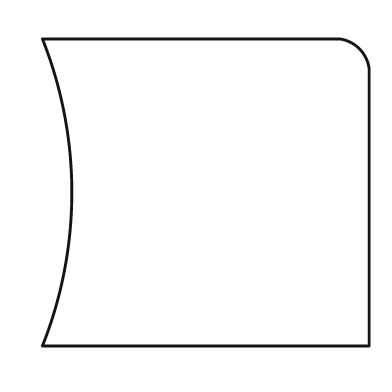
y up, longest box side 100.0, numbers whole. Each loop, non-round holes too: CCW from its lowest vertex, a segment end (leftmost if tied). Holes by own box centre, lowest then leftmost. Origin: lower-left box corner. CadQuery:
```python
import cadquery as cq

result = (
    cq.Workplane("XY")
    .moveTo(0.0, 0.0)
    .lineTo(100.0, 0.0)
    .lineTo(100.0, 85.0)
    .threePointArc((97.0, 91.0), (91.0, 94.0))
    .lineTo(0.0, 94.0)
    .threePointArc((9.0, 47.0), (0.0, 0.0))
    .close()
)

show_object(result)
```